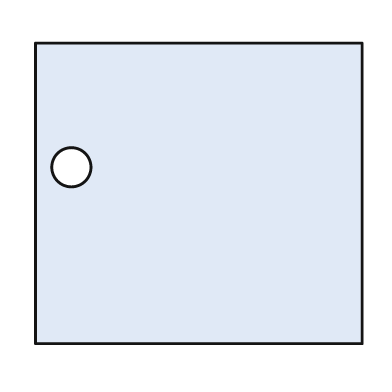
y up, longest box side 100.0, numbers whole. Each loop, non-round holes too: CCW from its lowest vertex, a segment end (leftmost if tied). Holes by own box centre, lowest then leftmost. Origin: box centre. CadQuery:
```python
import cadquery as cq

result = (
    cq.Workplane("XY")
    .moveTo(-50.0, -46.0)
    .lineTo(50.0, -46.0)
    .lineTo(50.0, 46.0)
    .lineTo(-50.0, 46.0)
    .close()
    .moveTo(-39.0, 8.0)
    .circle(6.0)
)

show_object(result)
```